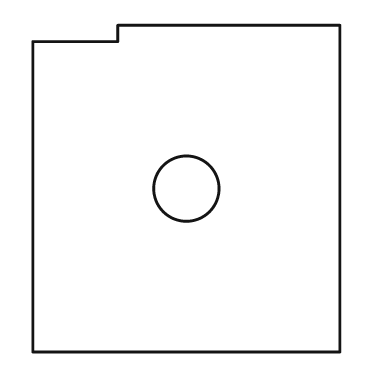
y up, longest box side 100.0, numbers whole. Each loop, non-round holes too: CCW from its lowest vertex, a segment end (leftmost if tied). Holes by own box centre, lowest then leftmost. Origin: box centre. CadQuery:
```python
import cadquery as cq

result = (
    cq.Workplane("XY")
    .moveTo(-47.0, -50.0)
    .lineTo(47.0, -50.0)
    .lineTo(47.0, 50.0)
    .lineTo(-21.0, 50.0)
    .lineTo(-21.0, 45.0)
    .lineTo(-47.0, 45.0)
    .close()
    .moveTo(0.0, 0.0)
    .circle(10.0)
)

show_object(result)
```